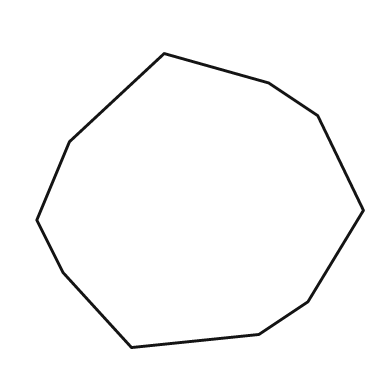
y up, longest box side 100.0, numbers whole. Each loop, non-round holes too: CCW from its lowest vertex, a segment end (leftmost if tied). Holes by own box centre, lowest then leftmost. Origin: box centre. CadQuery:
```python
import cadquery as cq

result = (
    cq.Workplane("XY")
    .moveTo(-21.0, -45.0)
    .lineTo(18.0, -41.0)
    .lineTo(33.0, -31.0)
    .lineTo(50.0, -3.0)
    .lineTo(36.0, 26.0)
    .lineTo(21.0, 36.0)
    .lineTo(-11.0, 45.0)
    .lineTo(-40.0, 18.0)
    .lineTo(-50.0, -6.0)
    .lineTo(-42.0, -22.0)
    .close()
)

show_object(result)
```